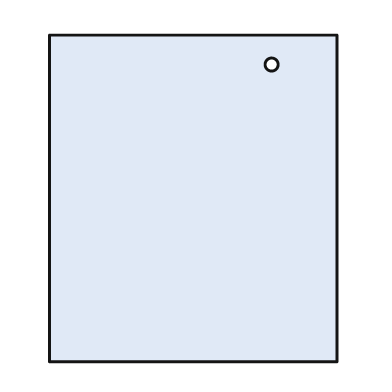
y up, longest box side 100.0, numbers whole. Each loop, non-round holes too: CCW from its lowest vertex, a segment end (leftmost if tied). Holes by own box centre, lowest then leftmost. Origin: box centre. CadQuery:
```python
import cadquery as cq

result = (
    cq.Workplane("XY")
    .moveTo(-44.0, -50.0)
    .lineTo(44.0, -50.0)
    .lineTo(44.0, 50.0)
    .lineTo(-44.0, 50.0)
    .close()
    .moveTo(24.0, 41.0)
    .circle(2.0)
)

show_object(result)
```